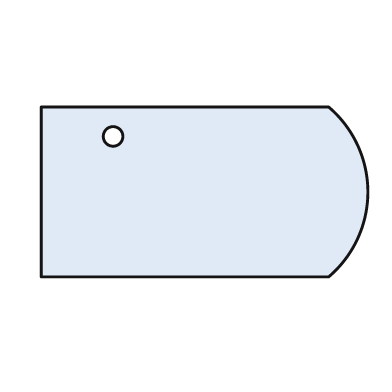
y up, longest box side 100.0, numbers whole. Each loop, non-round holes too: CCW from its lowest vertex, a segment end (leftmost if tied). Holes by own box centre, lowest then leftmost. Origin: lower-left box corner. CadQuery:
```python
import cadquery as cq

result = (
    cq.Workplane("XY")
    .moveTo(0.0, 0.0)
    .lineTo(88.0, 0.0)
    .threePointArc((100.0, 26.0), (88.0, 52.0))
    .lineTo(0.0, 52.0)
    .close()
    .moveTo(22.0, 43.0)
    .circle(3.0)
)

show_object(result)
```